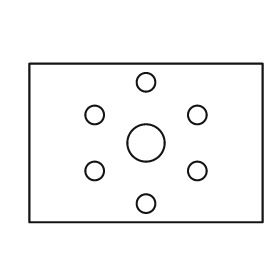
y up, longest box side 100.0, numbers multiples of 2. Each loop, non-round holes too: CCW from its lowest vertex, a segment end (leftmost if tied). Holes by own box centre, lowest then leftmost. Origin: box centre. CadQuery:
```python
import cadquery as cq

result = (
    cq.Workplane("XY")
    .moveTo(-50.0, -34.0)
    .lineTo(50.0, -34.0)
    .lineTo(50.0, 34.0)
    .lineTo(-50.0, 34.0)
    .close()
    .moveTo(0.0, -26.0)
    .circle(4.0)
    .moveTo(-22.0, -12.0)
    .circle(4.0)
    .moveTo(22.0, -12.0)
    .circle(4.0)
    .moveTo(0.0, 0.0)
    .circle(8.0)
    .moveTo(-22.0, 12.0)
    .circle(4.0)
    .moveTo(22.0, 12.0)
    .circle(4.0)
    .moveTo(0.0, 26.0)
    .circle(4.0)
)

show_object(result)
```